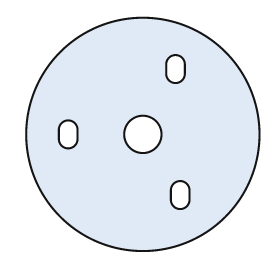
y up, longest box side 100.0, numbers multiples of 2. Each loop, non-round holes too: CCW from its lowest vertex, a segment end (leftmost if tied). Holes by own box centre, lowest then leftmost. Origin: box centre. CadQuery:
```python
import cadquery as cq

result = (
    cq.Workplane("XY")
    .moveTo(0.0, 0.0)
    .circle(50.0)
    .moveTo(12.0, -28.0)
    .threePointArc((16.0, -32.0), (20.0, -28.0))
    .lineTo(20.0, -24.0)
    .threePointArc((16.0, -20.0), (12.0, -24.0))
    .close()
    .moveTo(-36.0, -2.0)
    .threePointArc((-32.0, -6.0), (-28.0, -2.0))
    .lineTo(-28.0, 2.0)
    .threePointArc((-32.0, 6.0), (-36.0, 2.0))
    .close()
    .moveTo(0.0, 0.0)
    .circle(8.0)
    .moveTo(10.0, 26.0)
    .threePointArc((14.0, 22.0), (18.0, 26.0))
    .lineTo(18.0, 30.0)
    .threePointArc((14.0, 34.0), (10.0, 30.0))
    .close()
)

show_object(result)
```